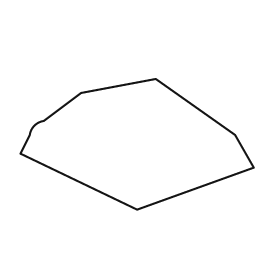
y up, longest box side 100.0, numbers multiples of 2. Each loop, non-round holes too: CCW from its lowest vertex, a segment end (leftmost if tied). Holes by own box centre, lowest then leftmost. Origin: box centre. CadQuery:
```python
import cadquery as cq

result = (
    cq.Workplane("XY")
    .moveTo(0.0, -28.0)
    .lineTo(50.0, -10.0)
    .lineTo(42.0, 4.0)
    .lineTo(8.0, 28.0)
    .lineTo(-24.0, 22.0)
    .lineTo(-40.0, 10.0)
    .threePointArc((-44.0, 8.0), (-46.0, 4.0))
    .lineTo(-50.0, -4.0)
    .close()
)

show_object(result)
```